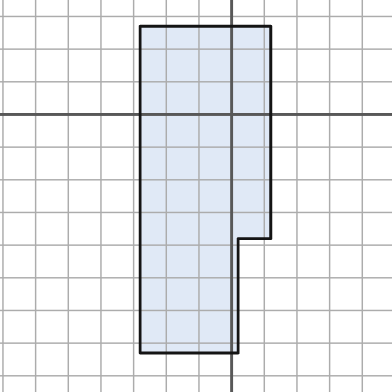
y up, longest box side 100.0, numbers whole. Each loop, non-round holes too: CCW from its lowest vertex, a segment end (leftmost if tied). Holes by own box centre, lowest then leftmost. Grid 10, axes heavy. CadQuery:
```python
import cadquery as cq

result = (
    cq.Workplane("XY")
    .moveTo(-28.0, -73.0)
    .lineTo(2.0, -73.0)
    .lineTo(2.0, -38.0)
    .lineTo(12.0, -38.0)
    .lineTo(12.0, 27.0)
    .lineTo(-28.0, 27.0)
    .close()
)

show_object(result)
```